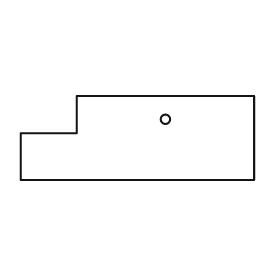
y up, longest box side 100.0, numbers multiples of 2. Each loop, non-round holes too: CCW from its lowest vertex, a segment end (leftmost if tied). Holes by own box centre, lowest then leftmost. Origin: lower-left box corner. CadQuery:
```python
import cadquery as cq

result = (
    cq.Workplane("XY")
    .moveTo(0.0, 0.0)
    .lineTo(100.0, 0.0)
    .lineTo(100.0, 36.0)
    .lineTo(24.0, 36.0)
    .lineTo(24.0, 20.0)
    .lineTo(0.0, 20.0)
    .close()
    .moveTo(62.0, 26.0)
    .circle(2.0)
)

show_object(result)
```